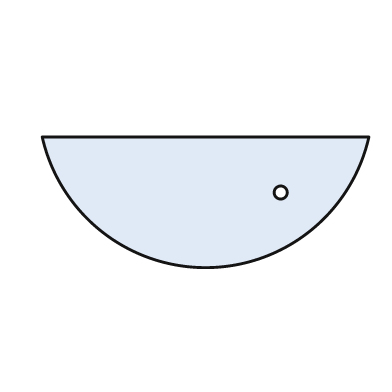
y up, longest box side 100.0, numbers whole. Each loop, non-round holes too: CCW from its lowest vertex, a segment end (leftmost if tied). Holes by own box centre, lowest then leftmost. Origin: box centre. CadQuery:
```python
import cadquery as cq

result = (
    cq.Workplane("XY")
    .moveTo(-50.0, 20.0)
    .threePointArc((0.0, -20.0), (50.0, 20.0))
    .close()
    .moveTo(23.0, 3.0)
    .circle(2.0)
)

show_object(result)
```